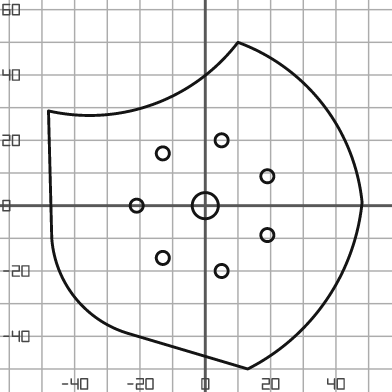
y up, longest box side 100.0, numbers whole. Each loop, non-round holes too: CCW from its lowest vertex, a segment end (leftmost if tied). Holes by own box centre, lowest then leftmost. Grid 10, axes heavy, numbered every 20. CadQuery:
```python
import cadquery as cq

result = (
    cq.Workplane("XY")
    .moveTo(13.0, -50.0)
    .threePointArc((37.0, -29.0), (48.0, 1.0))
    .threePointArc((36.0, 31.0), (10.0, 50.0))
    .threePointArc((-16.0, 31.0), (-48.0, 29.0))
    .lineTo(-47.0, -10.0)
    .threePointArc((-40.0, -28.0), (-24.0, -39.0))
    .close()
    .moveTo(5.0, -20.0)
    .circle(2.0)
    .moveTo(-13.0, -16.0)
    .circle(2.0)
    .moveTo(19.0, -9.0)
    .circle(2.0)
    .moveTo(-21.0, 0.0)
    .circle(2.0)
    .moveTo(0.0, 0.0)
    .circle(4.0)
    .moveTo(19.0, 9.0)
    .circle(2.0)
    .moveTo(-13.0, 16.0)
    .circle(2.0)
    .moveTo(5.0, 20.0)
    .circle(2.0)
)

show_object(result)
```